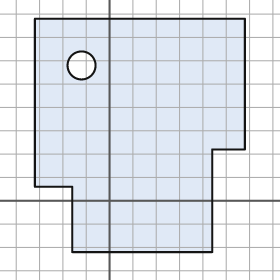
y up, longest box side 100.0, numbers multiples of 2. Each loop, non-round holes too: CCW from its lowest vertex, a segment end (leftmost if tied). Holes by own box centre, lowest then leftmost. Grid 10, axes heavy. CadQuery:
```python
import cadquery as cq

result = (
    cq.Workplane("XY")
    .moveTo(-16.0, -22.0)
    .lineTo(44.0, -22.0)
    .lineTo(44.0, 22.0)
    .lineTo(58.0, 22.0)
    .lineTo(58.0, 78.0)
    .lineTo(-32.0, 78.0)
    .lineTo(-32.0, 6.0)
    .lineTo(-16.0, 6.0)
    .close()
    .moveTo(-12.0, 58.0)
    .circle(6.0)
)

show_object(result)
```